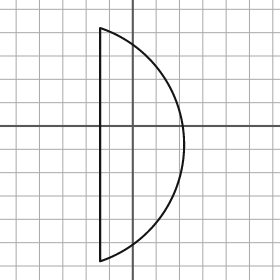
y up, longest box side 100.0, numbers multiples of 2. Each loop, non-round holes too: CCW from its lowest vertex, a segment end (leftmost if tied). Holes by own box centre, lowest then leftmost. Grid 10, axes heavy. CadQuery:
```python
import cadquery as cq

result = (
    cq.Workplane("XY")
    .moveTo(-14.0, -58.0)
    .threePointArc((22.0, -8.0), (-14.0, 42.0))
    .close()
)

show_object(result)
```